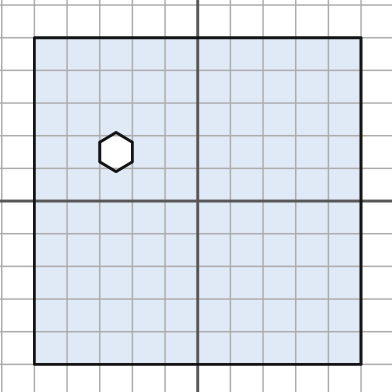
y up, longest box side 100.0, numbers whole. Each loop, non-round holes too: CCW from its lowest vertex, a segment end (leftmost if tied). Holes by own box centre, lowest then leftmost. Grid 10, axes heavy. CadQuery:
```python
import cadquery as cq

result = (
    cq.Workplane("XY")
    .moveTo(-50.0, -50.0)
    .lineTo(50.0, -50.0)
    .lineTo(50.0, 50.0)
    .lineTo(-50.0, 50.0)
    .close()
    .moveTo(-25.0, 9.0)
    .lineTo(-20.0, 12.0)
    .lineTo(-20.0, 18.0)
    .lineTo(-25.0, 21.0)
    .lineTo(-30.0, 18.0)
    .lineTo(-30.0, 12.0)
    .close()
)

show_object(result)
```